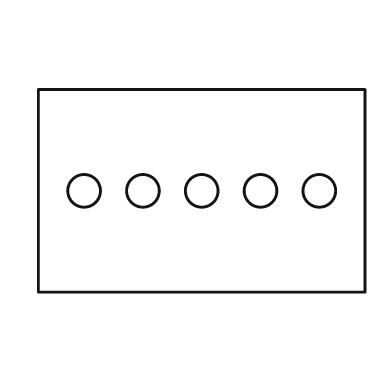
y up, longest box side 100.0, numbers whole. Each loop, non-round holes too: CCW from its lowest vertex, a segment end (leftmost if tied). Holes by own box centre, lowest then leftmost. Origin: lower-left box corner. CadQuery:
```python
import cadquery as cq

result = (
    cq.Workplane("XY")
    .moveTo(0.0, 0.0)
    .lineTo(100.0, 0.0)
    .lineTo(100.0, 62.0)
    .lineTo(0.0, 62.0)
    .close()
    .moveTo(14.0, 31.0)
    .circle(5.0)
    .moveTo(32.0, 31.0)
    .circle(5.0)
    .moveTo(50.0, 31.0)
    .circle(5.0)
    .moveTo(68.0, 31.0)
    .circle(5.0)
    .moveTo(86.0, 31.0)
    .circle(5.0)
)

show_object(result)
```